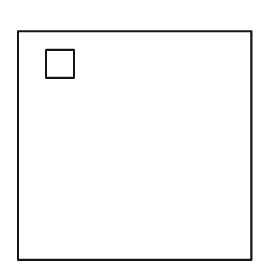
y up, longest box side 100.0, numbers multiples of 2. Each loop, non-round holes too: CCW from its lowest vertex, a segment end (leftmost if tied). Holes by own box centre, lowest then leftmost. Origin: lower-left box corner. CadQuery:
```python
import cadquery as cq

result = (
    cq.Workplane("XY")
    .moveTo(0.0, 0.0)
    .lineTo(100.0, 0.0)
    .lineTo(100.0, 98.0)
    .lineTo(0.0, 98.0)
    .close()
    .moveTo(12.0, 78.0)
    .lineTo(24.0, 78.0)
    .lineTo(24.0, 90.0)
    .lineTo(12.0, 90.0)
    .close()
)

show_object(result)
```